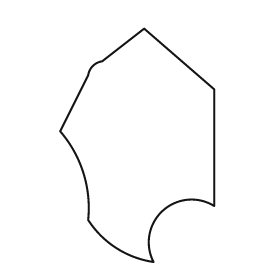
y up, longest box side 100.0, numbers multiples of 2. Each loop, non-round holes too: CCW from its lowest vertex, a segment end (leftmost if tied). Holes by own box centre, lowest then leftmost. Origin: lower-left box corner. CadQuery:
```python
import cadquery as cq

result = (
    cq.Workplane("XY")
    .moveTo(40.0, 0.0)
    .threePointArc((44.0, 22.0), (66.0, 24.0))
    .lineTo(66.0, 74.0)
    .lineTo(36.0, 100.0)
    .lineTo(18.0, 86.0)
    .threePointArc((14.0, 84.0), (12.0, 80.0))
    .lineTo(0.0, 56.0)
    .threePointArc((10.0, 38.0), (12.0, 18.0))
    .threePointArc((24.0, 6.0), (40.0, 0.0))
    .close()
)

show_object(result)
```